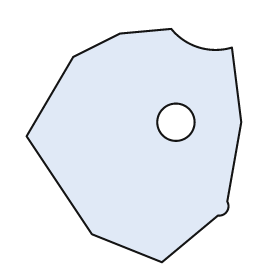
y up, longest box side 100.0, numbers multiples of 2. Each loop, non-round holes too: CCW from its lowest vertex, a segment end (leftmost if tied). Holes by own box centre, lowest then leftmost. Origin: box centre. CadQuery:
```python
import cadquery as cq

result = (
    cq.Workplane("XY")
    .moveTo(12.0, -50.0)
    .lineTo(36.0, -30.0)
    .threePointArc((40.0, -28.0), (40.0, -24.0))
    .lineTo(46.0, 10.0)
    .lineTo(42.0, 42.0)
    .threePointArc((28.0, 42.0), (16.0, 50.0))
    .lineTo(-6.0, 48.0)
    .lineTo(-26.0, 38.0)
    .lineTo(-46.0, 4.0)
    .lineTo(-18.0, -38.0)
    .close()
    .moveTo(18.0, 10.0)
    .circle(8.0)
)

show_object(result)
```